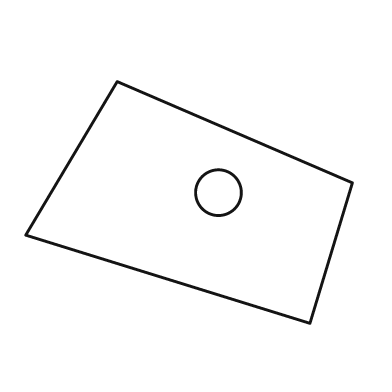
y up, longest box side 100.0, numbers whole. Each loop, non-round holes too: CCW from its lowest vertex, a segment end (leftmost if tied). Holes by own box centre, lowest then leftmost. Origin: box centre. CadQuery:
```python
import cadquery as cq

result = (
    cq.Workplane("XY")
    .moveTo(37.0, -37.0)
    .lineTo(50.0, 6.0)
    .lineTo(-22.0, 37.0)
    .lineTo(-50.0, -10.0)
    .close()
    .moveTo(9.0, 3.0)
    .circle(7.0)
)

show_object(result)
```